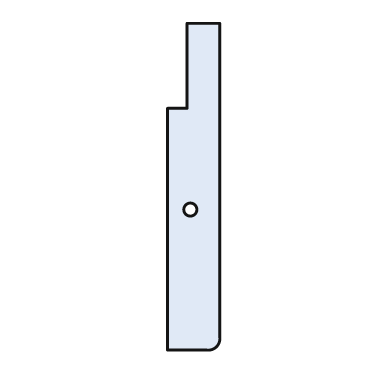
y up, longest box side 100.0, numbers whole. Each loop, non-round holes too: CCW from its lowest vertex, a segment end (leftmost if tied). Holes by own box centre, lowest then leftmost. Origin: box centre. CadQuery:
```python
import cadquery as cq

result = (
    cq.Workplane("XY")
    .moveTo(-8.0, -50.0)
    .lineTo(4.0, -50.0)
    .threePointArc((7.0, -49.0), (8.0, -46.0))
    .lineTo(8.0, 50.0)
    .lineTo(-2.0, 50.0)
    .lineTo(-2.0, 24.0)
    .lineTo(-8.0, 24.0)
    .close()
    .moveTo(-1.0, -7.0)
    .circle(2.0)
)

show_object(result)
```